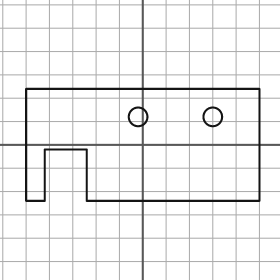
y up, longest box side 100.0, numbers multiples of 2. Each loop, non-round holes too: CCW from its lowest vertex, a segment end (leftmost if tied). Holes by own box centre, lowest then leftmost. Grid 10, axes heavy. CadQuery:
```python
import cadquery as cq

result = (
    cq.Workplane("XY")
    .moveTo(-50.0, -24.0)
    .lineTo(-42.0, -24.0)
    .lineTo(-42.0, -2.0)
    .lineTo(-24.0, -2.0)
    .lineTo(-24.0, -24.0)
    .lineTo(50.0, -24.0)
    .lineTo(50.0, 24.0)
    .lineTo(-50.0, 24.0)
    .close()
    .moveTo(-2.0, 12.0)
    .circle(4.0)
    .moveTo(30.0, 12.0)
    .circle(4.0)
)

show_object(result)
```